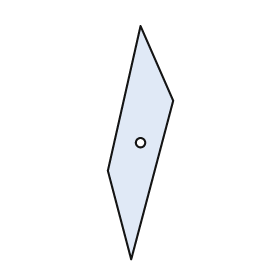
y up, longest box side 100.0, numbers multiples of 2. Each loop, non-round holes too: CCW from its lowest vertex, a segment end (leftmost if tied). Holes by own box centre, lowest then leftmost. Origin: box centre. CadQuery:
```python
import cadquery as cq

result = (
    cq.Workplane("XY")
    .moveTo(-4.0, -50.0)
    .lineTo(14.0, 18.0)
    .lineTo(0.0, 50.0)
    .lineTo(-14.0, -12.0)
    .close()
    .moveTo(0.0, 0.0)
    .circle(2.0)
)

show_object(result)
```